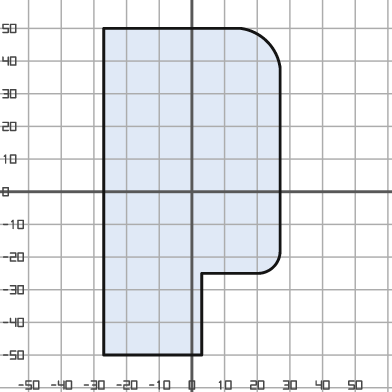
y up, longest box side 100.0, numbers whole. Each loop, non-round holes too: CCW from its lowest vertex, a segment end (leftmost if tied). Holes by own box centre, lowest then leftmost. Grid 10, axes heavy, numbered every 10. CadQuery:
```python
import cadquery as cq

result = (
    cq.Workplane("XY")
    .moveTo(-27.0, -50.0)
    .lineTo(3.0, -50.0)
    .lineTo(3.0, -25.0)
    .lineTo(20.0, -25.0)
    .threePointArc((25.0, -23.0), (27.0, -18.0))
    .lineTo(27.0, 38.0)
    .threePointArc((23.0, 46.0), (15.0, 50.0))
    .lineTo(-27.0, 50.0)
    .close()
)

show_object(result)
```